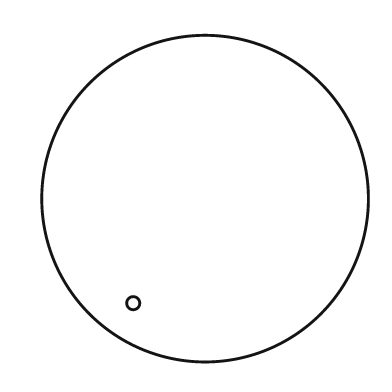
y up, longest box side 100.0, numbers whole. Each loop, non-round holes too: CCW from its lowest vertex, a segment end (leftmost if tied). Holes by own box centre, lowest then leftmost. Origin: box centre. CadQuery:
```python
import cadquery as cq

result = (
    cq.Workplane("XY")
    .moveTo(0.0, 0.0)
    .circle(50.0)
    .moveTo(-22.0, -32.0)
    .circle(2.0)
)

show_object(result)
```